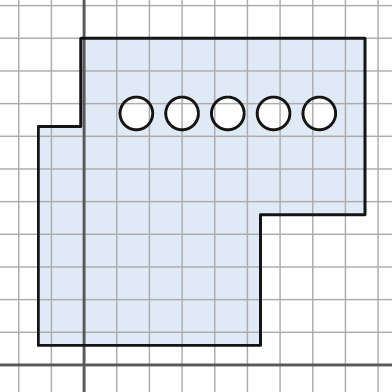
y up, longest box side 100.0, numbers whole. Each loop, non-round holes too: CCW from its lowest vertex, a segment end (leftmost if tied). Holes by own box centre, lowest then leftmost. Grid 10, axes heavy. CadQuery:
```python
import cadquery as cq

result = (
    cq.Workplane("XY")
    .moveTo(-14.0, 6.0)
    .lineTo(54.0, 6.0)
    .lineTo(54.0, 46.0)
    .lineTo(86.0, 46.0)
    .lineTo(86.0, 100.0)
    .lineTo(-1.0, 100.0)
    .lineTo(-1.0, 73.0)
    .lineTo(-14.0, 73.0)
    .close()
    .moveTo(16.0, 77.0)
    .circle(5.0)
    .moveTo(30.0, 77.0)
    .circle(5.0)
    .moveTo(44.0, 77.0)
    .circle(5.0)
    .moveTo(58.0, 77.0)
    .circle(5.0)
    .moveTo(72.0, 77.0)
    .circle(5.0)
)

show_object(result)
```